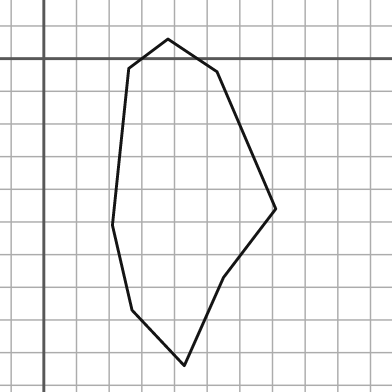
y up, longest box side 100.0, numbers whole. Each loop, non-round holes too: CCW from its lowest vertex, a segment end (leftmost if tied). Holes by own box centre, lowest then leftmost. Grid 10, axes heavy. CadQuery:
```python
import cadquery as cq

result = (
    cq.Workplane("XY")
    .moveTo(43.0, -94.0)
    .lineTo(55.0, -67.0)
    .lineTo(71.0, -46.0)
    .lineTo(53.0, -4.0)
    .lineTo(38.0, 6.0)
    .lineTo(26.0, -3.0)
    .lineTo(21.0, -51.0)
    .lineTo(27.0, -77.0)
    .close()
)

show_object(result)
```